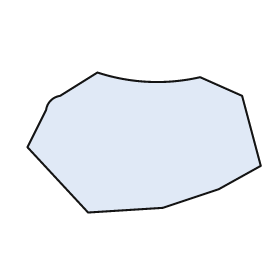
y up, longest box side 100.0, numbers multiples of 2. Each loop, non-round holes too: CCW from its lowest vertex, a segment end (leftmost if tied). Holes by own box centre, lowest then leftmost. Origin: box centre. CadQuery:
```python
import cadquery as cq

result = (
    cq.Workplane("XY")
    .moveTo(-24.0, -30.0)
    .lineTo(8.0, -28.0)
    .lineTo(32.0, -20.0)
    .lineTo(50.0, -10.0)
    .lineTo(42.0, 20.0)
    .lineTo(24.0, 28.0)
    .threePointArc((2.0, 26.0), (-20.0, 30.0))
    .lineTo(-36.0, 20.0)
    .threePointArc((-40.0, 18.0), (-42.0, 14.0))
    .lineTo(-50.0, -2.0)
    .close()
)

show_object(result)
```